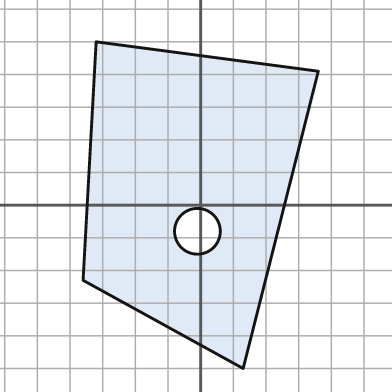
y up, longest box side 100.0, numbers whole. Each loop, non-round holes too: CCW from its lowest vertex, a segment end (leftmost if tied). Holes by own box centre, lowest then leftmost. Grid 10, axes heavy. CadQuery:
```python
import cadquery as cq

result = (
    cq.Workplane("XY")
    .moveTo(13.0, -50.0)
    .lineTo(36.0, 41.0)
    .lineTo(-32.0, 50.0)
    .lineTo(-36.0, -23.0)
    .close()
    .moveTo(-1.0, -8.0)
    .circle(7.0)
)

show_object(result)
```